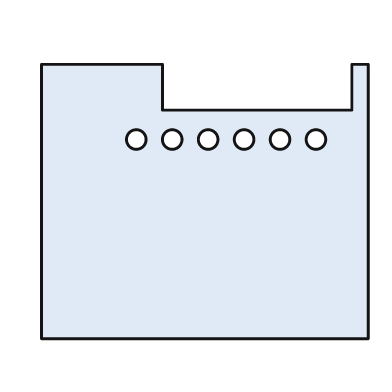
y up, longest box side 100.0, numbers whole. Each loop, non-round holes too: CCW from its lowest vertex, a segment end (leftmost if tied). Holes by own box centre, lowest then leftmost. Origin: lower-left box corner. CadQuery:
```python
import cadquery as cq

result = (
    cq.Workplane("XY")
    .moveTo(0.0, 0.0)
    .lineTo(100.0, 0.0)
    .lineTo(100.0, 84.0)
    .lineTo(95.0, 84.0)
    .lineTo(95.0, 70.0)
    .lineTo(37.0, 70.0)
    .lineTo(37.0, 84.0)
    .lineTo(0.0, 84.0)
    .close()
    .moveTo(29.0, 61.0)
    .circle(3.0)
    .moveTo(40.0, 61.0)
    .circle(3.0)
    .moveTo(51.0, 61.0)
    .circle(3.0)
    .moveTo(62.0, 61.0)
    .circle(3.0)
    .moveTo(73.0, 61.0)
    .circle(3.0)
    .moveTo(84.0, 61.0)
    .circle(3.0)
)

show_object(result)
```